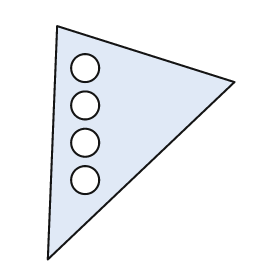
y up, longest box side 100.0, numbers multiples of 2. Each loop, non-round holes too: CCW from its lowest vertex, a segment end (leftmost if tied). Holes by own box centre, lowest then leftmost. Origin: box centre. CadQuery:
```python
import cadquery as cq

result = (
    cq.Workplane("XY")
    .moveTo(-40.0, -50.0)
    .lineTo(40.0, 26.0)
    .lineTo(-36.0, 50.0)
    .close()
    .moveTo(-24.0, -16.0)
    .circle(6.0)
    .moveTo(-24.0, 0.0)
    .circle(6.0)
    .moveTo(-24.0, 16.0)
    .circle(6.0)
    .moveTo(-24.0, 32.0)
    .circle(6.0)
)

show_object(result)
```